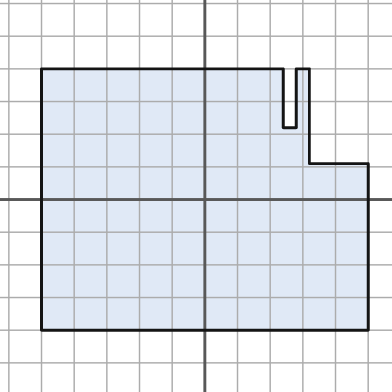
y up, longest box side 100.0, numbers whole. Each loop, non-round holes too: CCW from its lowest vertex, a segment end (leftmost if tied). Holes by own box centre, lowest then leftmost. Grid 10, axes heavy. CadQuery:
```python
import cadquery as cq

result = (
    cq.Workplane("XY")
    .moveTo(-50.0, -40.0)
    .lineTo(50.0, -40.0)
    .lineTo(50.0, 11.0)
    .lineTo(32.0, 11.0)
    .lineTo(32.0, 40.0)
    .lineTo(28.0, 40.0)
    .lineTo(28.0, 22.0)
    .lineTo(24.0, 22.0)
    .lineTo(24.0, 40.0)
    .lineTo(-50.0, 40.0)
    .close()
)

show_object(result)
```